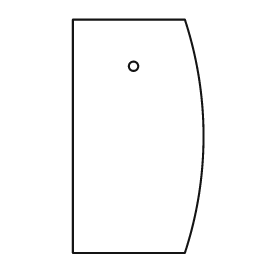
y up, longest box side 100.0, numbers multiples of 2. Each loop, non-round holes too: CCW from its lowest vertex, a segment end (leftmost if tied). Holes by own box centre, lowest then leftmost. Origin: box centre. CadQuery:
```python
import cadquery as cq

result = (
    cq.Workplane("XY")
    .moveTo(-28.0, -50.0)
    .lineTo(20.0, -50.0)
    .threePointArc((28.0, 0.0), (20.0, 50.0))
    .lineTo(-28.0, 50.0)
    .close()
    .moveTo(-2.0, 30.0)
    .circle(2.0)
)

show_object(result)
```